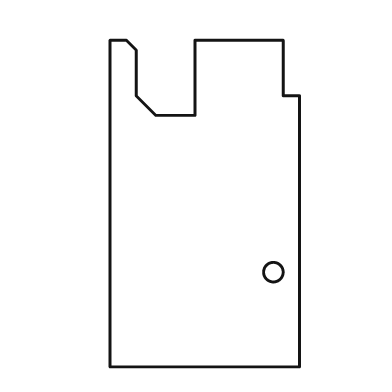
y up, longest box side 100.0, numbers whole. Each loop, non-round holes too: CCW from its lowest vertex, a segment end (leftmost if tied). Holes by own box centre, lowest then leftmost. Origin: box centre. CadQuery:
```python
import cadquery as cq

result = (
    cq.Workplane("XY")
    .moveTo(-29.0, -50.0)
    .lineTo(29.0, -50.0)
    .lineTo(29.0, 33.0)
    .lineTo(24.0, 33.0)
    .lineTo(24.0, 50.0)
    .lineTo(-3.0, 50.0)
    .lineTo(-3.0, 27.0)
    .lineTo(-15.0, 27.0)
    .lineTo(-21.0, 33.0)
    .lineTo(-21.0, 47.0)
    .lineTo(-24.0, 50.0)
    .lineTo(-29.0, 50.0)
    .close()
    .moveTo(21.0, -21.0)
    .circle(3.0)
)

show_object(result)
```